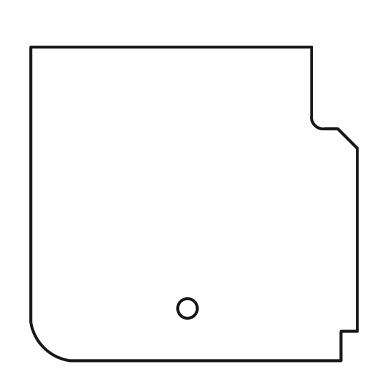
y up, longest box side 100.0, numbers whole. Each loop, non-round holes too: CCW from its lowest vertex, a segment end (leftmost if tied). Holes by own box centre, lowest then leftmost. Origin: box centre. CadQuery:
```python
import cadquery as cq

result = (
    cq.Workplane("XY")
    .moveTo(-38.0, -48.0)
    .lineTo(45.0, -48.0)
    .lineTo(45.0, -39.0)
    .lineTo(50.0, -39.0)
    .lineTo(50.0, 17.0)
    .lineTo(44.0, 23.0)
    .lineTo(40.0, 23.0)
    .threePointArc((37.0, 24.0), (36.0, 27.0))
    .lineTo(36.0, 48.0)
    .lineTo(-50.0, 48.0)
    .lineTo(-50.0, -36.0)
    .threePointArc((-46.0, -44.0), (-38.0, -48.0))
    .close()
    .moveTo(-2.0, -32.0)
    .circle(3.0)
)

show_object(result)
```